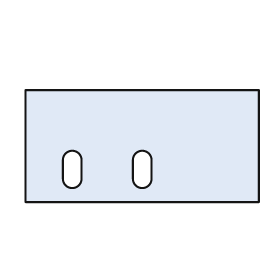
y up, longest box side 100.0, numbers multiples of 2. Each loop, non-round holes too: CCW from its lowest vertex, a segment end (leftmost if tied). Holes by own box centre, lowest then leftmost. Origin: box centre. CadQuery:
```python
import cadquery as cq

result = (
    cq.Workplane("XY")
    .moveTo(-50.0, -24.0)
    .lineTo(50.0, -24.0)
    .lineTo(50.0, 24.0)
    .lineTo(-50.0, 24.0)
    .close()
    .moveTo(-34.0, -14.0)
    .threePointArc((-30.0, -18.0), (-26.0, -14.0))
    .lineTo(-26.0, -6.0)
    .threePointArc((-30.0, -2.0), (-34.0, -6.0))
    .close()
    .moveTo(-4.0, -14.0)
    .threePointArc((0.0, -18.0), (4.0, -14.0))
    .lineTo(4.0, -6.0)
    .threePointArc((0.0, -2.0), (-4.0, -6.0))
    .close()
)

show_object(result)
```